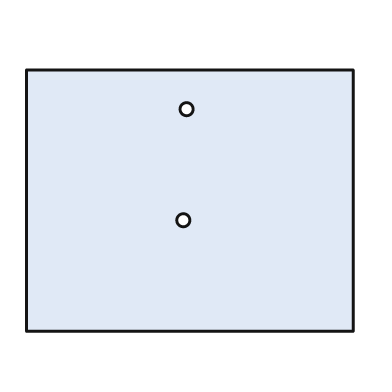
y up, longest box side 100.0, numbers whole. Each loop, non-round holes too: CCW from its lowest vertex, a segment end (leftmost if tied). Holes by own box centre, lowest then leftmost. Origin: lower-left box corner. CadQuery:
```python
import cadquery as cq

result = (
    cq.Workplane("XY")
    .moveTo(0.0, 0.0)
    .lineTo(100.0, 0.0)
    .lineTo(100.0, 80.0)
    .lineTo(0.0, 80.0)
    .close()
    .moveTo(48.0, 34.0)
    .circle(2.0)
    .moveTo(49.0, 68.0)
    .circle(2.0)
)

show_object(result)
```